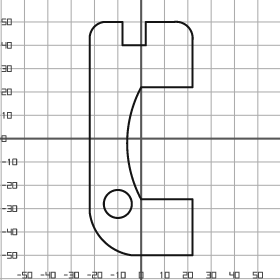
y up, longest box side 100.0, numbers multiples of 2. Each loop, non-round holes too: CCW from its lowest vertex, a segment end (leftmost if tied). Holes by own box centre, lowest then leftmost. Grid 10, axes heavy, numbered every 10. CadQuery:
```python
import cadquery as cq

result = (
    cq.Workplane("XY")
    .moveTo(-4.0, -50.0)
    .lineTo(22.0, -50.0)
    .lineTo(22.0, -26.0)
    .lineTo(0.0, -26.0)
    .threePointArc((-6.0, -2.0), (0.0, 22.0))
    .lineTo(22.0, 22.0)
    .lineTo(22.0, 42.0)
    .threePointArc((20.0, 48.0), (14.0, 50.0))
    .lineTo(2.0, 50.0)
    .lineTo(2.0, 40.0)
    .lineTo(-8.0, 40.0)
    .lineTo(-8.0, 50.0)
    .lineTo(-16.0, 50.0)
    .threePointArc((-20.0, 48.0), (-22.0, 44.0))
    .lineTo(-22.0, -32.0)
    .threePointArc((-16.0, -44.0), (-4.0, -50.0))
    .close()
    .moveTo(-10.0, -28.0)
    .circle(6.0)
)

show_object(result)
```